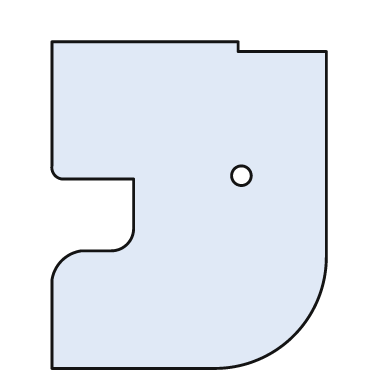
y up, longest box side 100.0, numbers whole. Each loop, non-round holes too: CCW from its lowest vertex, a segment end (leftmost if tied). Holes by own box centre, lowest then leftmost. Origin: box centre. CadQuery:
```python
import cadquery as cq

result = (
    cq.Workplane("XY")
    .moveTo(-42.0, -50.0)
    .lineTo(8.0, -50.0)
    .threePointArc((32.0, -40.0), (42.0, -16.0))
    .lineTo(42.0, 47.0)
    .lineTo(15.0, 47.0)
    .lineTo(15.0, 50.0)
    .lineTo(-42.0, 50.0)
    .lineTo(-42.0, 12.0)
    .threePointArc((-41.0, 9.0), (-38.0, 8.0))
    .lineTo(-17.0, 8.0)
    .lineTo(-17.0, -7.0)
    .threePointArc((-19.0, -12.0), (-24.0, -14.0))
    .lineTo(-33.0, -14.0)
    .threePointArc((-39.0, -17.0), (-42.0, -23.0))
    .close()
    .moveTo(16.0, 9.0)
    .circle(3.0)
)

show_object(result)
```